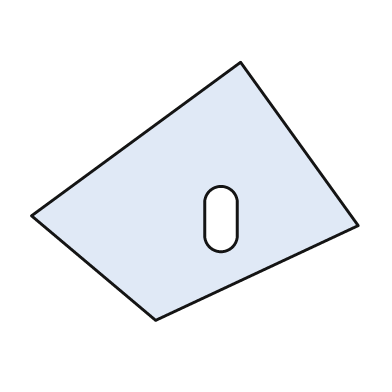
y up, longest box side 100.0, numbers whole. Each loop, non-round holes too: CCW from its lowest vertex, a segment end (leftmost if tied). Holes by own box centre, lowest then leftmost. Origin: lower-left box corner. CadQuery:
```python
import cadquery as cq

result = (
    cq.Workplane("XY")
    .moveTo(38.0, 0.0)
    .lineTo(100.0, 29.0)
    .lineTo(64.0, 79.0)
    .lineTo(0.0, 32.0)
    .close()
    .moveTo(53.0, 26.0)
    .threePointArc((58.0, 21.0), (63.0, 26.0))
    .lineTo(63.0, 36.0)
    .threePointArc((58.0, 41.0), (53.0, 36.0))
    .close()
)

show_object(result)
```